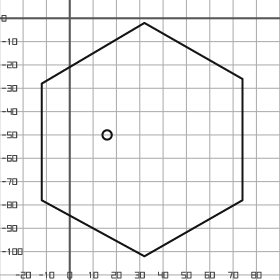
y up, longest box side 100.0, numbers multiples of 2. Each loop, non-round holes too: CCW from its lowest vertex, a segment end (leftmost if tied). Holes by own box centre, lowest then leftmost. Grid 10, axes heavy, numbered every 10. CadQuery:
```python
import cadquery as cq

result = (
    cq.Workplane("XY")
    .moveTo(32.0, -102.0)
    .lineTo(74.0, -78.0)
    .lineTo(74.0, -26.0)
    .lineTo(32.0, -2.0)
    .lineTo(-12.0, -28.0)
    .lineTo(-12.0, -78.0)
    .close()
    .moveTo(16.0, -50.0)
    .circle(2.0)
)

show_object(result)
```